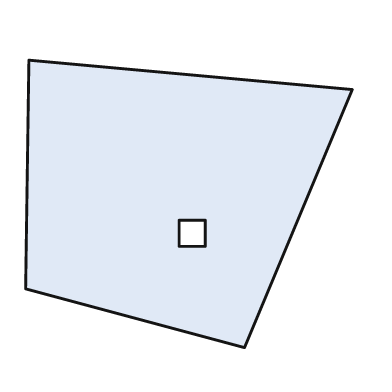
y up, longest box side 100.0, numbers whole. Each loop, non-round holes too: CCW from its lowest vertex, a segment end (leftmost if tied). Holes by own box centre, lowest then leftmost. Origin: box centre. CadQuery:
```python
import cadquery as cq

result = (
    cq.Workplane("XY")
    .moveTo(17.0, -44.0)
    .lineTo(50.0, 35.0)
    .lineTo(-49.0, 44.0)
    .lineTo(-50.0, -26.0)
    .close()
    .moveTo(-3.0, -13.0)
    .lineTo(5.0, -13.0)
    .lineTo(5.0, -5.0)
    .lineTo(-3.0, -5.0)
    .close()
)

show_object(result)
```